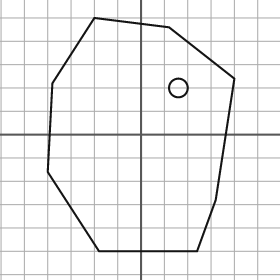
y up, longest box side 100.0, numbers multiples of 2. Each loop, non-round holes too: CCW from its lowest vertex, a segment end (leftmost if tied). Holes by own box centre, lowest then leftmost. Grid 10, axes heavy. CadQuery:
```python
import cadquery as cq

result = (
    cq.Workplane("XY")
    .moveTo(-18.0, -50.0)
    .lineTo(24.0, -50.0)
    .lineTo(32.0, -28.0)
    .lineTo(40.0, 24.0)
    .lineTo(12.0, 46.0)
    .lineTo(-20.0, 50.0)
    .lineTo(-38.0, 22.0)
    .lineTo(-40.0, -16.0)
    .close()
    .moveTo(16.0, 20.0)
    .circle(4.0)
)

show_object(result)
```